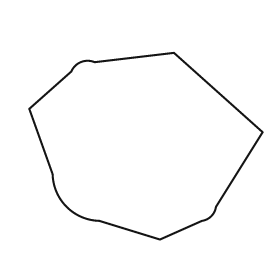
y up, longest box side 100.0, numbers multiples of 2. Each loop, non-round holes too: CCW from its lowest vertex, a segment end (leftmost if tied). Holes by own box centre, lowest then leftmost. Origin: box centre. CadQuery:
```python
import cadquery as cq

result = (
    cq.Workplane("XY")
    .moveTo(6.0, -40.0)
    .lineTo(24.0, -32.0)
    .threePointArc((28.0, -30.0), (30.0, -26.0))
    .lineTo(50.0, 6.0)
    .lineTo(12.0, 40.0)
    .lineTo(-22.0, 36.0)
    .threePointArc((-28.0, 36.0), (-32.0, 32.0))
    .lineTo(-50.0, 16.0)
    .lineTo(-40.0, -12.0)
    .threePointArc((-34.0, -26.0), (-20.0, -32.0))
    .close()
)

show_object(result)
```